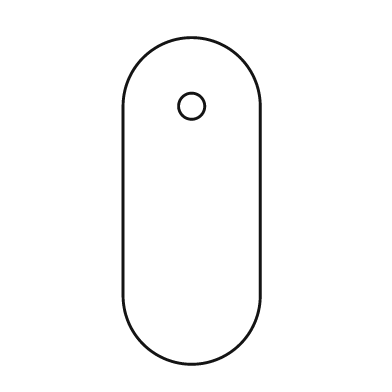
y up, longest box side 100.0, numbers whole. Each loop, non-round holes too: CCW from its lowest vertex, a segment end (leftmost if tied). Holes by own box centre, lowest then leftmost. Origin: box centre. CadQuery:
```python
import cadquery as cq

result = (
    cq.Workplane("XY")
    .moveTo(-21.0, -29.0)
    .threePointArc((0.0, -50.0), (21.0, -29.0))
    .lineTo(21.0, 29.0)
    .threePointArc((0.0, 50.0), (-21.0, 29.0))
    .close()
    .moveTo(0.0, 29.0)
    .circle(4.0)
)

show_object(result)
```